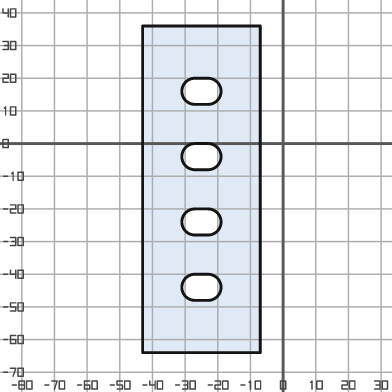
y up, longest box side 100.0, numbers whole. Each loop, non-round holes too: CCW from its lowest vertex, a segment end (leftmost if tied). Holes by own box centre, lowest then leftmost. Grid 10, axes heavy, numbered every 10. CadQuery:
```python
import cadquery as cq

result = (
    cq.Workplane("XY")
    .moveTo(-43.0, -64.0)
    .lineTo(-7.0, -64.0)
    .lineTo(-7.0, 36.0)
    .lineTo(-43.0, 36.0)
    .close()
    .moveTo(-27.0, -48.0)
    .lineTo(-23.0, -48.0)
    .threePointArc((-19.0, -44.0), (-23.0, -40.0))
    .lineTo(-27.0, -40.0)
    .threePointArc((-31.0, -44.0), (-27.0, -48.0))
    .close()
    .moveTo(-27.0, -28.0)
    .lineTo(-23.0, -28.0)
    .threePointArc((-19.0, -24.0), (-23.0, -20.0))
    .lineTo(-27.0, -20.0)
    .threePointArc((-31.0, -24.0), (-27.0, -28.0))
    .close()
    .moveTo(-27.0, -8.0)
    .lineTo(-23.0, -8.0)
    .threePointArc((-19.0, -4.0), (-23.0, 0.0))
    .lineTo(-27.0, 0.0)
    .threePointArc((-31.0, -4.0), (-27.0, -8.0))
    .close()
    .moveTo(-27.0, 12.0)
    .lineTo(-23.0, 12.0)
    .threePointArc((-19.0, 16.0), (-23.0, 20.0))
    .lineTo(-27.0, 20.0)
    .threePointArc((-31.0, 16.0), (-27.0, 12.0))
    .close()
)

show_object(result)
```